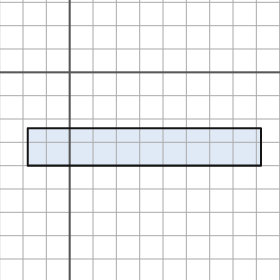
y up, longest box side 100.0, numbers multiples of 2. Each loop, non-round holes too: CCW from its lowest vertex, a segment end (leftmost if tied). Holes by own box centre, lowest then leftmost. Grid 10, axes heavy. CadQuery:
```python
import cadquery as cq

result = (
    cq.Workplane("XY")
    .moveTo(-18.0, -40.0)
    .lineTo(82.0, -40.0)
    .lineTo(82.0, -24.0)
    .lineTo(-18.0, -24.0)
    .close()
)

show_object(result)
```